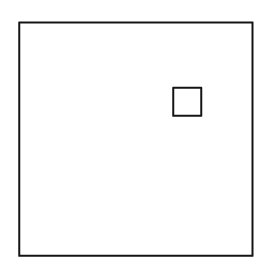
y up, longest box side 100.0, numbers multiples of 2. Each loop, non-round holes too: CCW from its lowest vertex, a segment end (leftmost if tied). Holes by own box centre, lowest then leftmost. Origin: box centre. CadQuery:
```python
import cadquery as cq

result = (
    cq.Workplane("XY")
    .moveTo(-50.0, -50.0)
    .lineTo(50.0, -50.0)
    .lineTo(50.0, 50.0)
    .lineTo(-50.0, 50.0)
    .close()
    .moveTo(16.0, 10.0)
    .lineTo(28.0, 10.0)
    .lineTo(28.0, 22.0)
    .lineTo(16.0, 22.0)
    .close()
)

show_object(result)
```